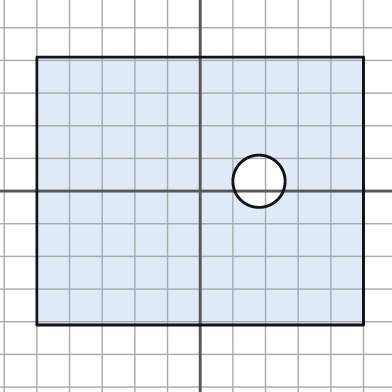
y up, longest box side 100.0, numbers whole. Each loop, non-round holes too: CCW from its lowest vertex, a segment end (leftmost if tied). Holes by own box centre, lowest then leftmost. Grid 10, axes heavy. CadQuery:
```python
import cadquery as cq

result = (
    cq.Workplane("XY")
    .moveTo(-50.0, -41.0)
    .lineTo(50.0, -41.0)
    .lineTo(50.0, 41.0)
    .lineTo(-50.0, 41.0)
    .close()
    .moveTo(18.0, 3.0)
    .circle(8.0)
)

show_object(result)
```